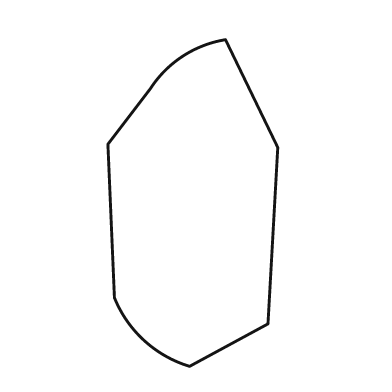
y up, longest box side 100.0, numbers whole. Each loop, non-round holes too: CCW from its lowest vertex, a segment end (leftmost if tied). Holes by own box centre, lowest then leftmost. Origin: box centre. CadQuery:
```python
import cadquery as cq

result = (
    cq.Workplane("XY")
    .moveTo(-1.0, -50.0)
    .lineTo(23.0, -37.0)
    .lineTo(26.0, 17.0)
    .lineTo(10.0, 50.0)
    .threePointArc((-3.0, 45.0), (-13.0, 35.0))
    .lineTo(-26.0, 18.0)
    .lineTo(-24.0, -29.0)
    .threePointArc((-15.0, -42.0), (-1.0, -50.0))
    .close()
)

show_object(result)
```